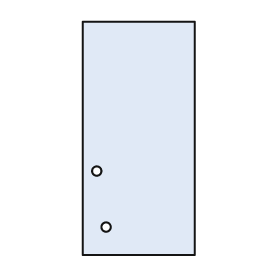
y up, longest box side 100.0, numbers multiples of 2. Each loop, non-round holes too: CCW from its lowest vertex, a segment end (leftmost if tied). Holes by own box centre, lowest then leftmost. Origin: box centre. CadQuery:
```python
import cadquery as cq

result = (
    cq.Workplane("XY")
    .moveTo(-24.0, -50.0)
    .lineTo(24.0, -50.0)
    .lineTo(24.0, 50.0)
    .lineTo(-24.0, 50.0)
    .close()
    .moveTo(-14.0, -38.0)
    .circle(2.0)
    .moveTo(-18.0, -14.0)
    .circle(2.0)
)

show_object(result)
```